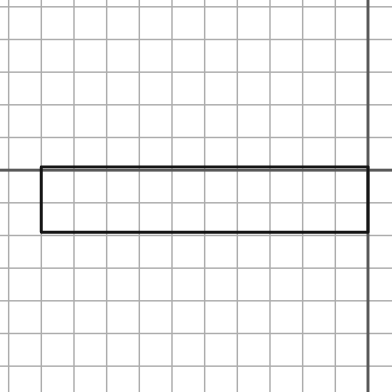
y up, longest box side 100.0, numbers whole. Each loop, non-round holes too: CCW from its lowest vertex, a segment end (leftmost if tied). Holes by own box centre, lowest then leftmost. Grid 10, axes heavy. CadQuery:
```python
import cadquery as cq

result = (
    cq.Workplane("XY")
    .moveTo(-100.0, -19.0)
    .lineTo(0.0, -19.0)
    .lineTo(0.0, 1.0)
    .lineTo(-100.0, 1.0)
    .close()
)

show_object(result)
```